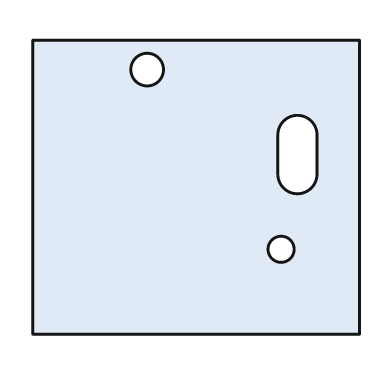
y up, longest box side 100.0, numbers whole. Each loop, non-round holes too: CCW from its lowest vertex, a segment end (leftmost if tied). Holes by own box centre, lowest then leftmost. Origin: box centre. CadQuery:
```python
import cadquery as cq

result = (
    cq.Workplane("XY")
    .moveTo(-50.0, -45.0)
    .lineTo(50.0, -45.0)
    .lineTo(50.0, 45.0)
    .lineTo(-50.0, 45.0)
    .close()
    .moveTo(26.0, -19.0)
    .circle(4.0)
    .moveTo(25.0, 4.0)
    .threePointArc((31.0, -2.0), (37.0, 4.0))
    .lineTo(37.0, 16.0)
    .threePointArc((31.0, 22.0), (25.0, 16.0))
    .close()
    .moveTo(-15.0, 36.0)
    .circle(5.0)
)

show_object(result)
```